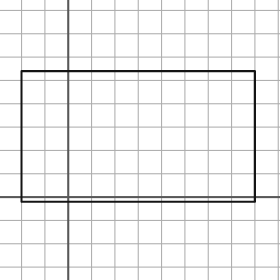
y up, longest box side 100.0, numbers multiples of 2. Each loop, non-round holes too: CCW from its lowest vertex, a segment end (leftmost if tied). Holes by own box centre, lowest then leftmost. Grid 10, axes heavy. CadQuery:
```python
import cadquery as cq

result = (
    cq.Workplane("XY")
    .moveTo(-20.0, -2.0)
    .lineTo(80.0, -2.0)
    .lineTo(80.0, 54.0)
    .lineTo(-20.0, 54.0)
    .close()
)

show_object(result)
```